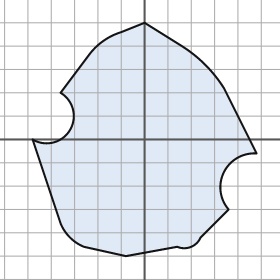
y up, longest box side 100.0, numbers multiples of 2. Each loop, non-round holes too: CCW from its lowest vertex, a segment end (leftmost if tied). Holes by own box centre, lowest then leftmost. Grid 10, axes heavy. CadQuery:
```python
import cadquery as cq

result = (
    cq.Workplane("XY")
    .moveTo(-8.0, -50.0)
    .lineTo(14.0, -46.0)
    .threePointArc((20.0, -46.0), (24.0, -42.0))
    .lineTo(36.0, -30.0)
    .threePointArc((34.0, -14.0), (48.0, -6.0))
    .lineTo(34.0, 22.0)
    .threePointArc((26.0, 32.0), (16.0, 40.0))
    .lineTo(0.0, 50.0)
    .lineTo(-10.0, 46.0)
    .threePointArc((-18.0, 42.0), (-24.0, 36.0))
    .lineTo(-36.0, 20.0)
    .threePointArc((-32.0, 4.0), (-48.0, 0.0))
    .lineTo(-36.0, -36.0)
    .threePointArc((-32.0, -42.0), (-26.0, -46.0))
    .close()
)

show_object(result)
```